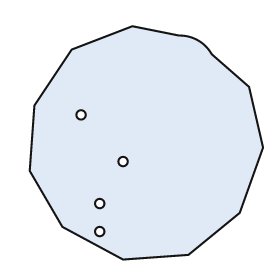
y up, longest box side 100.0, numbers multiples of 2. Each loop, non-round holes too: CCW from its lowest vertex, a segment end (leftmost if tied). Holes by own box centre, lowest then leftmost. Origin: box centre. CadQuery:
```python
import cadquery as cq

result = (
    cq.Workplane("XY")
    .moveTo(-10.0, -50.0)
    .lineTo(18.0, -48.0)
    .lineTo(40.0, -30.0)
    .lineTo(50.0, -2.0)
    .lineTo(44.0, 24.0)
    .lineTo(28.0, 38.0)
    .threePointArc((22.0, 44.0), (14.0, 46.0))
    .lineTo(-6.0, 50.0)
    .lineTo(-32.0, 40.0)
    .lineTo(-48.0, 16.0)
    .lineTo(-50.0, -12.0)
    .lineTo(-36.0, -36.0)
    .close()
    .moveTo(-20.0, -38.0)
    .circle(2.0)
    .moveTo(-20.0, -26.0)
    .circle(2.0)
    .moveTo(-10.0, -8.0)
    .circle(2.0)
    .moveTo(-28.0, 12.0)
    .circle(2.0)
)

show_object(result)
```